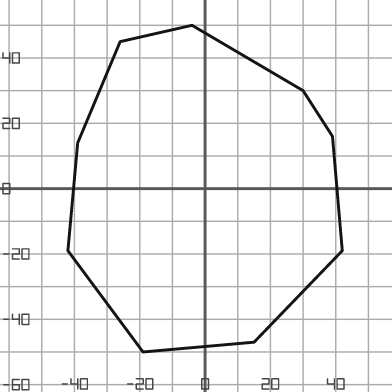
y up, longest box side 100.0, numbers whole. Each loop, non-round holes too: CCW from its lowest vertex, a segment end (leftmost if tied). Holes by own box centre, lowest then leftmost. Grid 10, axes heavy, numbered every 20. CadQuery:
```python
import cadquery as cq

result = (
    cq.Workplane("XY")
    .moveTo(-19.0, -50.0)
    .lineTo(15.0, -47.0)
    .lineTo(42.0, -19.0)
    .lineTo(39.0, 16.0)
    .lineTo(30.0, 30.0)
    .lineTo(-4.0, 50.0)
    .lineTo(-26.0, 45.0)
    .lineTo(-39.0, 14.0)
    .lineTo(-42.0, -19.0)
    .close()
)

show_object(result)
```